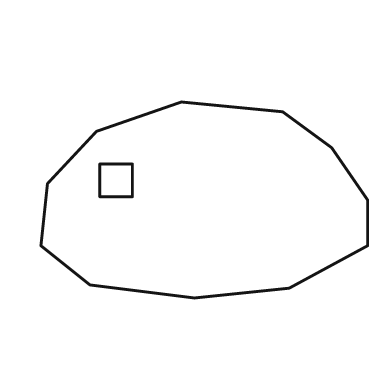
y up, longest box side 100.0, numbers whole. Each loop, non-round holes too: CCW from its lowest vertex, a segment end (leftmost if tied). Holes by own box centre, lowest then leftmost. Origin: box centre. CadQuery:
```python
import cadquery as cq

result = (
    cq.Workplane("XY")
    .moveTo(-3.0, -30.0)
    .lineTo(26.0, -27.0)
    .lineTo(50.0, -14.0)
    .lineTo(50.0, 0.0)
    .lineTo(39.0, 16.0)
    .lineTo(24.0, 27.0)
    .lineTo(-7.0, 30.0)
    .lineTo(-33.0, 21.0)
    .lineTo(-48.0, 5.0)
    .lineTo(-50.0, -14.0)
    .lineTo(-35.0, -26.0)
    .close()
    .moveTo(-32.0, 1.0)
    .lineTo(-22.0, 1.0)
    .lineTo(-22.0, 11.0)
    .lineTo(-32.0, 11.0)
    .close()
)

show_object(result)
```